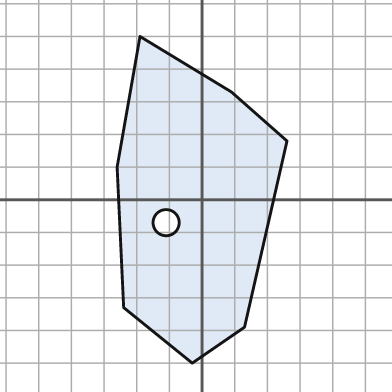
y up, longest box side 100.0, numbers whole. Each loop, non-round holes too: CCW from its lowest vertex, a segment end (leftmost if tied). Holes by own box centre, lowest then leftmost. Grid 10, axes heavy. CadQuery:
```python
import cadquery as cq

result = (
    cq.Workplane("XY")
    .moveTo(-3.0, -50.0)
    .lineTo(13.0, -39.0)
    .lineTo(26.0, 18.0)
    .lineTo(9.0, 33.0)
    .lineTo(-19.0, 50.0)
    .lineTo(-26.0, 10.0)
    .lineTo(-24.0, -33.0)
    .close()
    .moveTo(-11.0, -7.0)
    .circle(4.0)
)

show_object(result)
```